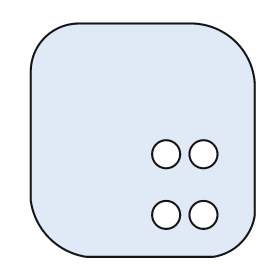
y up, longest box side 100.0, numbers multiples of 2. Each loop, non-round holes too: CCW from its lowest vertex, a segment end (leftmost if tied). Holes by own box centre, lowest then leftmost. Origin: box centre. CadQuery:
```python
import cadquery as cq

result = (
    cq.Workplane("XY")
    .moveTo(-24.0, -50.0)
    .lineTo(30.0, -50.0)
    .threePointArc((42.0, -44.0), (48.0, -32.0))
    .lineTo(48.0, 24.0)
    .threePointArc((40.0, 42.0), (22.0, 50.0))
    .lineTo(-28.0, 50.0)
    .threePointArc((-42.0, 44.0), (-48.0, 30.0))
    .lineTo(-48.0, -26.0)
    .threePointArc((-40.0, -42.0), (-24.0, -50.0))
    .close()
    .moveTo(10.0, -32.0)
    .circle(6.0)
    .moveTo(26.0, -32.0)
    .circle(6.0)
    .moveTo(10.0, -6.0)
    .circle(6.0)
    .moveTo(26.0, -6.0)
    .circle(6.0)
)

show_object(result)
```